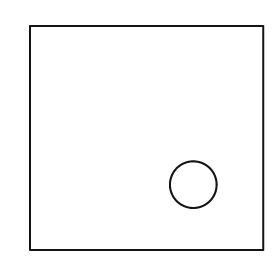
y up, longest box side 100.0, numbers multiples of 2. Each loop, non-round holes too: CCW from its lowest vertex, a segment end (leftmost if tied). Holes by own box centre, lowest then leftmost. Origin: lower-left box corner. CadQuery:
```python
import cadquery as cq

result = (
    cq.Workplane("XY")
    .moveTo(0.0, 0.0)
    .lineTo(100.0, 0.0)
    .lineTo(100.0, 96.0)
    .lineTo(0.0, 96.0)
    .close()
    .moveTo(70.0, 28.0)
    .circle(10.0)
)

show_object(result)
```